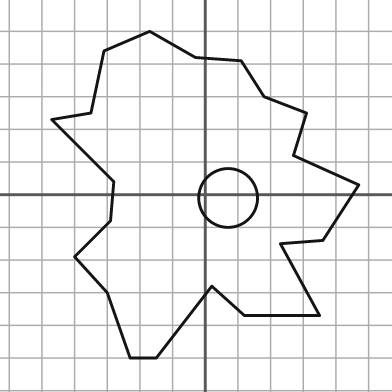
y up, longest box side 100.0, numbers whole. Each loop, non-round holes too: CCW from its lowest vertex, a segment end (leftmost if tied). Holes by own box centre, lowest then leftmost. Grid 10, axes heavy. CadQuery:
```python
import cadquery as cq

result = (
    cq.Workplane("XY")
    .moveTo(-23.0, -50.0)
    .lineTo(-15.0, -50.0)
    .lineTo(2.0, -28.0)
    .lineTo(12.0, -37.0)
    .lineTo(35.0, -37.0)
    .lineTo(23.0, -15.0)
    .lineTo(36.0, -14.0)
    .lineTo(47.0, 3.0)
    .lineTo(27.0, 12.0)
    .lineTo(31.0, 25.0)
    .lineTo(18.0, 30.0)
    .lineTo(11.0, 41.0)
    .lineTo(-3.0, 42.0)
    .lineTo(-17.0, 50.0)
    .lineTo(-31.0, 44.0)
    .lineTo(-35.0, 25.0)
    .lineTo(-47.0, 23.0)
    .lineTo(-28.0, 4.0)
    .lineTo(-29.0, -8.0)
    .lineTo(-40.0, -19.0)
    .lineTo(-30.0, -30.0)
    .close()
    .moveTo(7.0, -1.0)
    .circle(9.0)
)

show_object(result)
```